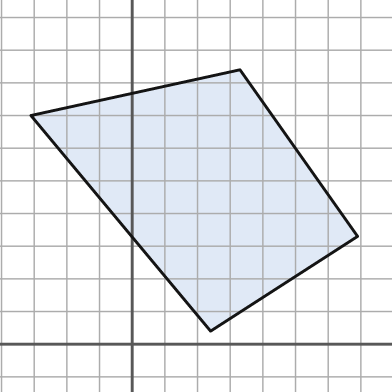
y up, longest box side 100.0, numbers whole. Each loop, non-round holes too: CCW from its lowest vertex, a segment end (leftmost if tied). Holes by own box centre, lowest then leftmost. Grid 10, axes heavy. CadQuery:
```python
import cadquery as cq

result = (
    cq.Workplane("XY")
    .moveTo(24.0, 4.0)
    .lineTo(69.0, 33.0)
    .lineTo(33.0, 84.0)
    .lineTo(-31.0, 70.0)
    .close()
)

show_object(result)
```